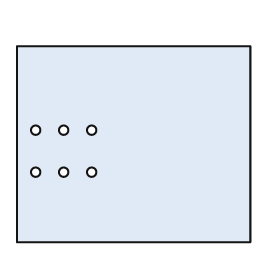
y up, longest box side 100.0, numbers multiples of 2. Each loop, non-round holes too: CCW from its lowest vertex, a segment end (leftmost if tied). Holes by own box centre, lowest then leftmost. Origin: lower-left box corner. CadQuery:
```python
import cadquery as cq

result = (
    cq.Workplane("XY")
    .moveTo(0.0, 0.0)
    .lineTo(100.0, 0.0)
    .lineTo(100.0, 84.0)
    .lineTo(0.0, 84.0)
    .close()
    .moveTo(8.0, 30.0)
    .circle(2.0)
    .moveTo(20.0, 30.0)
    .circle(2.0)
    .moveTo(32.0, 30.0)
    .circle(2.0)
    .moveTo(8.0, 48.0)
    .circle(2.0)
    .moveTo(20.0, 48.0)
    .circle(2.0)
    .moveTo(32.0, 48.0)
    .circle(2.0)
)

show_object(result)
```